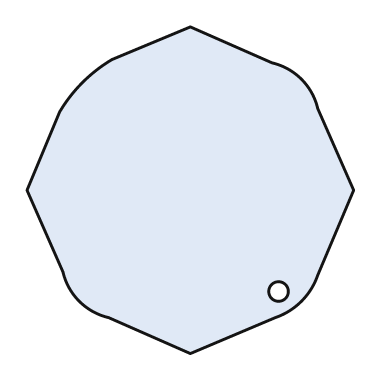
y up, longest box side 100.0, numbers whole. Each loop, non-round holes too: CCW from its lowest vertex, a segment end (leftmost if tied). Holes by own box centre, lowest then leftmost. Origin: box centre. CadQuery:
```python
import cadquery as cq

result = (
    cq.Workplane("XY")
    .moveTo(0.0, -50.0)
    .lineTo(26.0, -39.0)
    .threePointArc((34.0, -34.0), (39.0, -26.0))
    .lineTo(50.0, 0.0)
    .lineTo(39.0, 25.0)
    .threePointArc((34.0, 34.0), (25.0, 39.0))
    .lineTo(0.0, 50.0)
    .lineTo(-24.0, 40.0)
    .threePointArc((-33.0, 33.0), (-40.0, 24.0))
    .lineTo(-50.0, 0.0)
    .lineTo(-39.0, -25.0)
    .threePointArc((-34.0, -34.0), (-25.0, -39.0))
    .close()
    .moveTo(27.0, -31.0)
    .circle(3.0)
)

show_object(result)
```